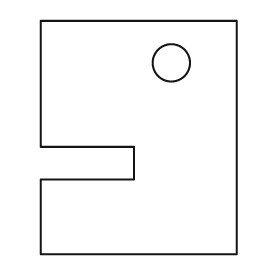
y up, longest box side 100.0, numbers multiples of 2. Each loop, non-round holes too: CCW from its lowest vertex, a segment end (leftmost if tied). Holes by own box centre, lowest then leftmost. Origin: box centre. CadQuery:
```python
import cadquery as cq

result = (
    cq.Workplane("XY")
    .moveTo(-42.0, -50.0)
    .lineTo(42.0, -50.0)
    .lineTo(42.0, 50.0)
    .lineTo(-42.0, 50.0)
    .lineTo(-42.0, -4.0)
    .lineTo(-2.0, -4.0)
    .lineTo(-2.0, -18.0)
    .lineTo(-42.0, -18.0)
    .close()
    .moveTo(14.0, 32.0)
    .circle(8.0)
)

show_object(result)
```